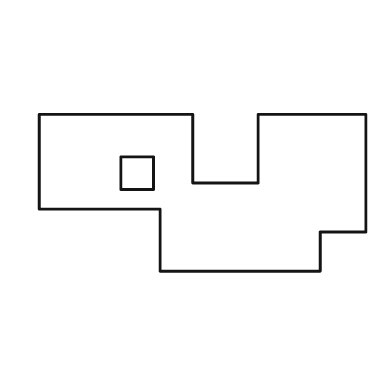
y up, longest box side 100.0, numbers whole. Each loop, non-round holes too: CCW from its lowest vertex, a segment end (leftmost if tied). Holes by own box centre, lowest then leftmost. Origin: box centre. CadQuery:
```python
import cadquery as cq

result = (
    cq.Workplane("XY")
    .moveTo(-13.0, -24.0)
    .lineTo(36.0, -24.0)
    .lineTo(36.0, -12.0)
    .lineTo(50.0, -12.0)
    .lineTo(50.0, 24.0)
    .lineTo(17.0, 24.0)
    .lineTo(17.0, 3.0)
    .lineTo(-3.0, 3.0)
    .lineTo(-3.0, 24.0)
    .lineTo(-50.0, 24.0)
    .lineTo(-50.0, -5.0)
    .lineTo(-13.0, -5.0)
    .close()
    .moveTo(-25.0, 1.0)
    .lineTo(-15.0, 1.0)
    .lineTo(-15.0, 11.0)
    .lineTo(-25.0, 11.0)
    .close()
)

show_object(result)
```